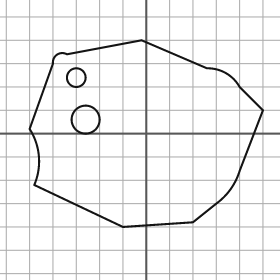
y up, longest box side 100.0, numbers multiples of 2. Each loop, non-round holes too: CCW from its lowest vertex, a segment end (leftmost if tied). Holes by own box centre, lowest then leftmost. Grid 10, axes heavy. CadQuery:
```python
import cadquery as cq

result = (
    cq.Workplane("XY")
    .moveTo(-10.0, -40.0)
    .lineTo(20.0, -38.0)
    .lineTo(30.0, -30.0)
    .threePointArc((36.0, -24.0), (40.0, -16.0))
    .lineTo(50.0, 10.0)
    .lineTo(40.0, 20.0)
    .threePointArc((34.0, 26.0), (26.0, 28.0))
    .lineTo(-2.0, 40.0)
    .lineTo(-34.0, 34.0)
    .threePointArc((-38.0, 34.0), (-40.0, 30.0))
    .lineTo(-50.0, 2.0)
    .threePointArc((-46.0, -10.0), (-48.0, -22.0))
    .close()
    .moveTo(-26.0, 6.0)
    .circle(6.0)
    .moveTo(-30.0, 24.0)
    .circle(4.0)
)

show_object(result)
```